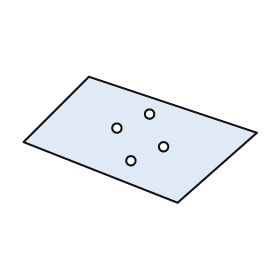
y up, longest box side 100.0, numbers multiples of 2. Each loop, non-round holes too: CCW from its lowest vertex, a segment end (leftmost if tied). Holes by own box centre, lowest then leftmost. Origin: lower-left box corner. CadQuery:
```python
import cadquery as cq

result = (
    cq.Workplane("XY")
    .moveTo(66.0, 0.0)
    .lineTo(100.0, 30.0)
    .lineTo(28.0, 54.0)
    .lineTo(0.0, 26.0)
    .close()
    .moveTo(46.0, 18.0)
    .circle(2.0)
    .moveTo(60.0, 24.0)
    .circle(2.0)
    .moveTo(40.0, 32.0)
    .circle(2.0)
    .moveTo(54.0, 38.0)
    .circle(2.0)
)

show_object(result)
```